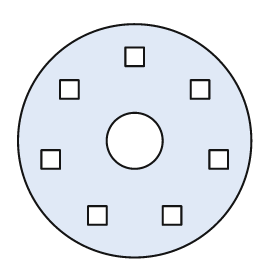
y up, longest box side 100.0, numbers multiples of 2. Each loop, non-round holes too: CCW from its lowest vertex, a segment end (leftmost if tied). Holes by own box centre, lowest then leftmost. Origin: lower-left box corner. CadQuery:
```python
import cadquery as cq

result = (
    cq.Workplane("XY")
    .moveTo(50.0, 50.0)
    .circle(50.0)
    .moveTo(30.0, 14.0)
    .lineTo(38.0, 14.0)
    .lineTo(38.0, 22.0)
    .lineTo(30.0, 22.0)
    .close()
    .moveTo(62.0, 14.0)
    .lineTo(70.0, 14.0)
    .lineTo(70.0, 22.0)
    .lineTo(62.0, 22.0)
    .close()
    .moveTo(10.0, 38.0)
    .lineTo(18.0, 38.0)
    .lineTo(18.0, 46.0)
    .lineTo(10.0, 46.0)
    .close()
    .moveTo(82.0, 38.0)
    .lineTo(90.0, 38.0)
    .lineTo(90.0, 46.0)
    .lineTo(82.0, 46.0)
    .close()
    .moveTo(50.0, 50.0)
    .circle(12.0)
    .moveTo(18.0, 68.0)
    .lineTo(26.0, 68.0)
    .lineTo(26.0, 76.0)
    .lineTo(18.0, 76.0)
    .close()
    .moveTo(74.0, 68.0)
    .lineTo(82.0, 68.0)
    .lineTo(82.0, 76.0)
    .lineTo(74.0, 76.0)
    .close()
    .moveTo(46.0, 82.0)
    .lineTo(54.0, 82.0)
    .lineTo(54.0, 90.0)
    .lineTo(46.0, 90.0)
    .close()
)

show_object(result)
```